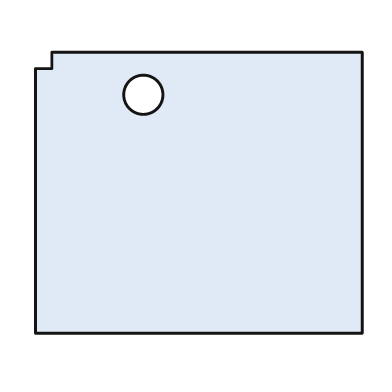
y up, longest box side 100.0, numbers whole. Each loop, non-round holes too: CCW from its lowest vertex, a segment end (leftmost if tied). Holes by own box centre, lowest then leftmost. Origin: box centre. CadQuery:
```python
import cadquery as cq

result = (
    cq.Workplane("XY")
    .moveTo(-50.0, -43.0)
    .lineTo(50.0, -43.0)
    .lineTo(50.0, 43.0)
    .lineTo(-45.0, 43.0)
    .lineTo(-45.0, 38.0)
    .lineTo(-50.0, 38.0)
    .close()
    .moveTo(-17.0, 30.0)
    .circle(6.0)
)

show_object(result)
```